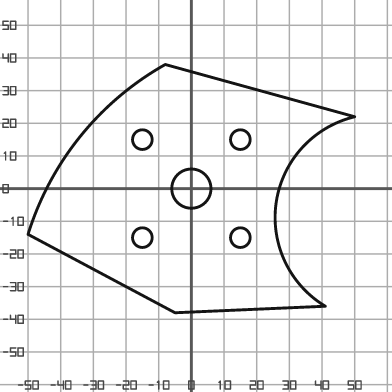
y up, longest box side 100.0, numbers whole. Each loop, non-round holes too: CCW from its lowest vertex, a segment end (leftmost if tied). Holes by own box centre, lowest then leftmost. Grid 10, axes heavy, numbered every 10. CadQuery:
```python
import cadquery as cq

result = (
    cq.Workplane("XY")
    .moveTo(-5.0, -38.0)
    .lineTo(41.0, -36.0)
    .threePointArc((26.0, -4.0), (50.0, 22.0))
    .lineTo(-8.0, 38.0)
    .threePointArc((-34.0, 16.0), (-50.0, -14.0))
    .close()
    .moveTo(-15.0, -15.0)
    .circle(3.0)
    .moveTo(15.0, -15.0)
    .circle(3.0)
    .moveTo(0.0, 0.0)
    .circle(6.0)
    .moveTo(-15.0, 15.0)
    .circle(3.0)
    .moveTo(15.0, 15.0)
    .circle(3.0)
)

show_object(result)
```